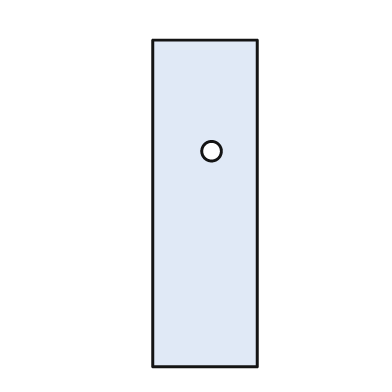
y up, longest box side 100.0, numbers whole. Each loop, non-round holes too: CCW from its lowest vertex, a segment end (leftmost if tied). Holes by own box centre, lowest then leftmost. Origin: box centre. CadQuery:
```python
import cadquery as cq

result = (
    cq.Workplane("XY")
    .moveTo(-16.0, -50.0)
    .lineTo(16.0, -50.0)
    .lineTo(16.0, 50.0)
    .lineTo(-16.0, 50.0)
    .close()
    .moveTo(2.0, 16.0)
    .circle(3.0)
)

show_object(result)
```